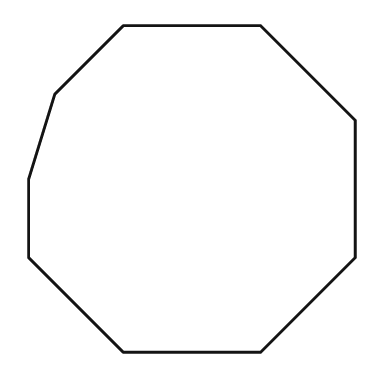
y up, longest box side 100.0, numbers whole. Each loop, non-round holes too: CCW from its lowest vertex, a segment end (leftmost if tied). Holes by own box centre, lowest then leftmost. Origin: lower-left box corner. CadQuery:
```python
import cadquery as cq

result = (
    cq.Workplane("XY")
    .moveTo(29.0, 0.0)
    .lineTo(71.0, 0.0)
    .lineTo(100.0, 29.0)
    .lineTo(100.0, 71.0)
    .lineTo(71.0, 100.0)
    .lineTo(29.0, 100.0)
    .lineTo(8.0, 79.0)
    .lineTo(0.0, 53.0)
    .lineTo(0.0, 29.0)
    .close()
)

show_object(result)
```